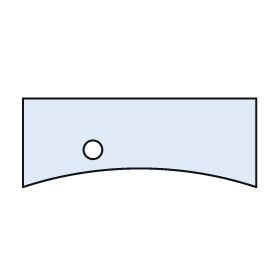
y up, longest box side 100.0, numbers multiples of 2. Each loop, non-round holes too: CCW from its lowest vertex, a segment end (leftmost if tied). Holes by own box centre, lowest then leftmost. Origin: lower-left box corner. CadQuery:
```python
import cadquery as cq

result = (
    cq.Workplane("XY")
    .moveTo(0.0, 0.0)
    .threePointArc((50.0, 8.0), (100.0, 0.0))
    .lineTo(100.0, 38.0)
    .lineTo(0.0, 38.0)
    .close()
    .moveTo(30.0, 16.0)
    .circle(4.0)
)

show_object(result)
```